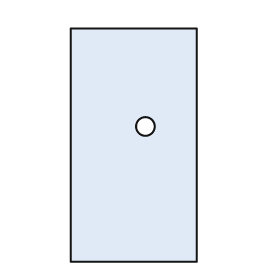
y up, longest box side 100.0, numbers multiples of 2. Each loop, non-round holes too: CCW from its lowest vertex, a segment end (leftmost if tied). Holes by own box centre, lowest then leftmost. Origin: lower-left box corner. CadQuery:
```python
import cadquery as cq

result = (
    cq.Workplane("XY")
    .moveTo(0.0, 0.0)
    .lineTo(54.0, 0.0)
    .lineTo(54.0, 100.0)
    .lineTo(0.0, 100.0)
    .close()
    .moveTo(32.0, 58.0)
    .circle(4.0)
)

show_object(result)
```